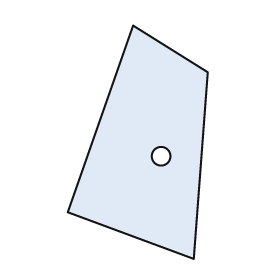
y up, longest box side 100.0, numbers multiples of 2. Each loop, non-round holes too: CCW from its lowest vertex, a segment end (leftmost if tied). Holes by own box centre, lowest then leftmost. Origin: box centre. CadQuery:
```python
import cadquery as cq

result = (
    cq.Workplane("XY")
    .moveTo(24.0, -50.0)
    .lineTo(30.0, 30.0)
    .lineTo(-2.0, 50.0)
    .lineTo(-30.0, -30.0)
    .close()
    .moveTo(10.0, -6.0)
    .circle(4.0)
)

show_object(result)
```